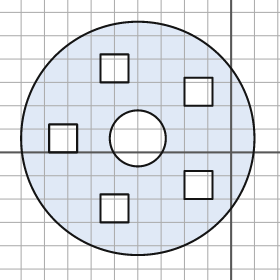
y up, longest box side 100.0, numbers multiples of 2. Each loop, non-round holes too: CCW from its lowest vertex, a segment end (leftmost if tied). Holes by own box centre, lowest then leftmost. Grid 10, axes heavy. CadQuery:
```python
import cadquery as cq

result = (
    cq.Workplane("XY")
    .moveTo(-40.0, 6.0)
    .circle(50.0)
    .moveTo(-56.0, -30.0)
    .lineTo(-44.0, -30.0)
    .lineTo(-44.0, -18.0)
    .lineTo(-56.0, -18.0)
    .close()
    .moveTo(-20.0, -20.0)
    .lineTo(-8.0, -20.0)
    .lineTo(-8.0, -8.0)
    .lineTo(-20.0, -8.0)
    .close()
    .moveTo(-78.0, 0.0)
    .lineTo(-66.0, 0.0)
    .lineTo(-66.0, 12.0)
    .lineTo(-78.0, 12.0)
    .close()
    .moveTo(-40.0, 6.0)
    .circle(12.0)
    .moveTo(-20.0, 20.0)
    .lineTo(-8.0, 20.0)
    .lineTo(-8.0, 32.0)
    .lineTo(-20.0, 32.0)
    .close()
    .moveTo(-56.0, 30.0)
    .lineTo(-44.0, 30.0)
    .lineTo(-44.0, 42.0)
    .lineTo(-56.0, 42.0)
    .close()
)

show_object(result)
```